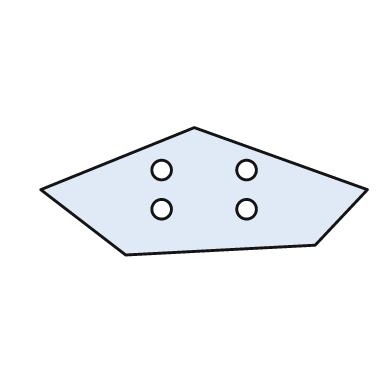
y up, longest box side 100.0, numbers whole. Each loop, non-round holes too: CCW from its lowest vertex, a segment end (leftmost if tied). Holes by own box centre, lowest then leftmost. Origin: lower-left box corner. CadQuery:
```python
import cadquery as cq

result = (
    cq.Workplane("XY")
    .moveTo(26.0, 0.0)
    .lineTo(84.0, 3.0)
    .lineTo(100.0, 20.0)
    .lineTo(47.0, 39.0)
    .lineTo(0.0, 20.0)
    .close()
    .moveTo(37.0, 14.0)
    .circle(3.0)
    .moveTo(63.0, 14.0)
    .circle(3.0)
    .moveTo(37.0, 26.0)
    .circle(3.0)
    .moveTo(63.0, 26.0)
    .circle(3.0)
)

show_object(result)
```